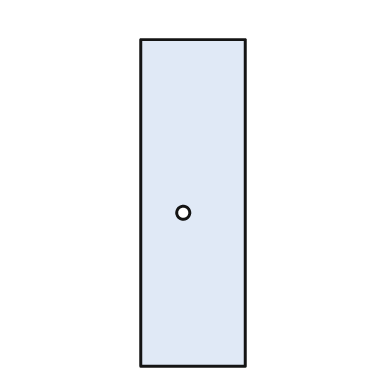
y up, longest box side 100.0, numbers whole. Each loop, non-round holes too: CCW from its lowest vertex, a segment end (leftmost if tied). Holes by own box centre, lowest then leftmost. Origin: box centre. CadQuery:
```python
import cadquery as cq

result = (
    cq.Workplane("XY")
    .moveTo(-16.0, -50.0)
    .lineTo(16.0, -50.0)
    .lineTo(16.0, 50.0)
    .lineTo(-16.0, 50.0)
    .close()
    .moveTo(-3.0, -3.0)
    .circle(2.0)
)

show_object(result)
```